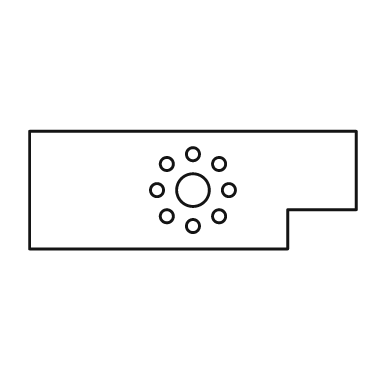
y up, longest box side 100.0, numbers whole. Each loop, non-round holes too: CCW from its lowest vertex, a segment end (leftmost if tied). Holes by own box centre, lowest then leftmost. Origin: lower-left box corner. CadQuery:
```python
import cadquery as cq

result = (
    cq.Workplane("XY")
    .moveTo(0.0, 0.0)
    .lineTo(79.0, 0.0)
    .lineTo(79.0, 12.0)
    .lineTo(100.0, 12.0)
    .lineTo(100.0, 36.0)
    .lineTo(0.0, 36.0)
    .close()
    .moveTo(50.0, 7.0)
    .circle(2.0)
    .moveTo(42.0, 10.0)
    .circle(2.0)
    .moveTo(58.0, 10.0)
    .circle(2.0)
    .moveTo(39.0, 18.0)
    .circle(2.0)
    .moveTo(50.0, 18.0)
    .circle(5.0)
    .moveTo(61.0, 18.0)
    .circle(2.0)
    .moveTo(42.0, 26.0)
    .circle(2.0)
    .moveTo(58.0, 26.0)
    .circle(2.0)
    .moveTo(50.0, 29.0)
    .circle(2.0)
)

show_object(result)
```